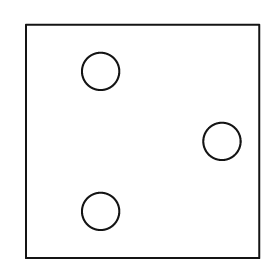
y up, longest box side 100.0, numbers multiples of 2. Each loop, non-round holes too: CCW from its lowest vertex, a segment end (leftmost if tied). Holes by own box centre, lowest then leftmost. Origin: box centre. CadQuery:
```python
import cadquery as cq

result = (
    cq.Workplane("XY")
    .moveTo(-50.0, -50.0)
    .lineTo(50.0, -50.0)
    .lineTo(50.0, 50.0)
    .lineTo(-50.0, 50.0)
    .close()
    .moveTo(-18.0, -30.0)
    .circle(8.0)
    .moveTo(34.0, 0.0)
    .circle(8.0)
    .moveTo(-18.0, 30.0)
    .circle(8.0)
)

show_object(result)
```